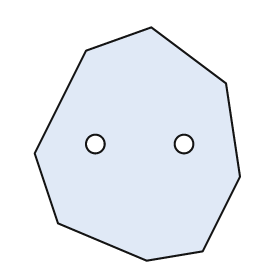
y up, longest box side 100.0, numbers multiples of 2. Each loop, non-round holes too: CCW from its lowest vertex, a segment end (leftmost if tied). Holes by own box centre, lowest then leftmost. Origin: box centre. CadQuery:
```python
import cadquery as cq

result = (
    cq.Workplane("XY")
    .moveTo(4.0, -50.0)
    .lineTo(28.0, -46.0)
    .lineTo(44.0, -14.0)
    .lineTo(38.0, 26.0)
    .lineTo(6.0, 50.0)
    .lineTo(-22.0, 40.0)
    .lineTo(-44.0, -4.0)
    .lineTo(-34.0, -34.0)
    .close()
    .moveTo(-18.0, 0.0)
    .circle(4.0)
    .moveTo(20.0, 0.0)
    .circle(4.0)
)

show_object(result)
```